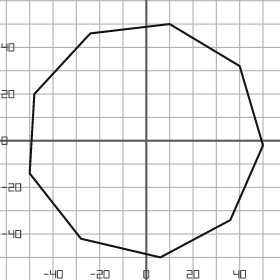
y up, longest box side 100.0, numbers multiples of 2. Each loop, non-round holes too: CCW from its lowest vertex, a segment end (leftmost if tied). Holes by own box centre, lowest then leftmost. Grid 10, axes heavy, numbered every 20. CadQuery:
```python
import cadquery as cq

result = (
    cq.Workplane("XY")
    .moveTo(6.0, -50.0)
    .lineTo(36.0, -34.0)
    .lineTo(50.0, -2.0)
    .lineTo(40.0, 32.0)
    .lineTo(10.0, 50.0)
    .lineTo(-24.0, 46.0)
    .lineTo(-48.0, 20.0)
    .lineTo(-50.0, -14.0)
    .lineTo(-28.0, -42.0)
    .close()
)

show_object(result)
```